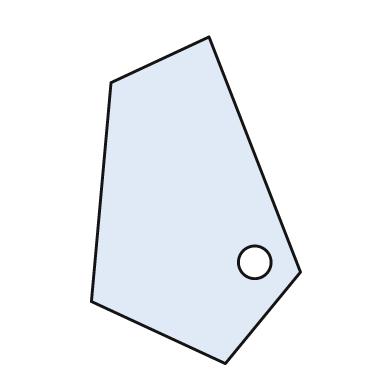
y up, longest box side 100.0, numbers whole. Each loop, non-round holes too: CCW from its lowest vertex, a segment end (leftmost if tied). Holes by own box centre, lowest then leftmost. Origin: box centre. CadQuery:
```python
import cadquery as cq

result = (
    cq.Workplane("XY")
    .moveTo(9.0, -50.0)
    .lineTo(32.0, -22.0)
    .lineTo(4.0, 50.0)
    .lineTo(-26.0, 36.0)
    .lineTo(-32.0, -31.0)
    .close()
    .moveTo(18.0, -19.0)
    .circle(5.0)
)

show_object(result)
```